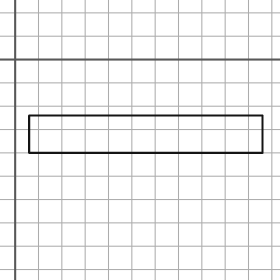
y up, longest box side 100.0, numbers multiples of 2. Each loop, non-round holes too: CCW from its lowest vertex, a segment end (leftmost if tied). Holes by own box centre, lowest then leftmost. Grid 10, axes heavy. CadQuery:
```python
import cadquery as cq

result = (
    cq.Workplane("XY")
    .moveTo(6.0, -40.0)
    .lineTo(106.0, -40.0)
    .lineTo(106.0, -24.0)
    .lineTo(6.0, -24.0)
    .close()
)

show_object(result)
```